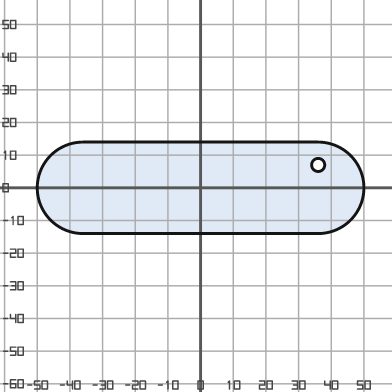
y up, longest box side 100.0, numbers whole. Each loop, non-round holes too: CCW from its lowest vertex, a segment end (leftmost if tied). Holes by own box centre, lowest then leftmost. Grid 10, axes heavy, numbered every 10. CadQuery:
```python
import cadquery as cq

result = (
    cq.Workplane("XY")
    .moveTo(-36.0, -14.0)
    .lineTo(36.0, -14.0)
    .threePointArc((50.0, 0.0), (36.0, 14.0))
    .lineTo(-36.0, 14.0)
    .threePointArc((-50.0, 0.0), (-36.0, -14.0))
    .close()
    .moveTo(36.0, 7.0)
    .circle(2.0)
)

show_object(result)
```